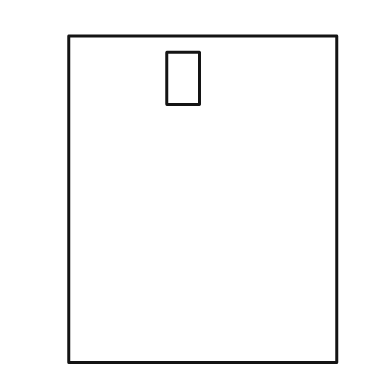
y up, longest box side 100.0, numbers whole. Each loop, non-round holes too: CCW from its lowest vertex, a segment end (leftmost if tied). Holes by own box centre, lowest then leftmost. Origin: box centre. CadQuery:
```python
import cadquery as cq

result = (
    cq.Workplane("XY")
    .moveTo(-41.0, -50.0)
    .lineTo(41.0, -50.0)
    .lineTo(41.0, 50.0)
    .lineTo(-41.0, 50.0)
    .close()
    .moveTo(-11.0, 29.0)
    .lineTo(-1.0, 29.0)
    .lineTo(-1.0, 45.0)
    .lineTo(-11.0, 45.0)
    .close()
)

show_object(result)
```